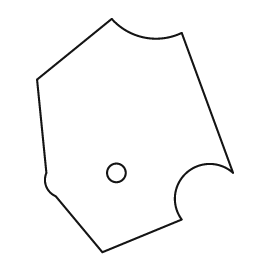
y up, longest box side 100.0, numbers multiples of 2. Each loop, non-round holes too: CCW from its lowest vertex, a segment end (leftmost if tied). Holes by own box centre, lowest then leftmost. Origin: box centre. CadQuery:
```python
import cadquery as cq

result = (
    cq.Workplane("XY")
    .moveTo(-14.0, -50.0)
    .lineTo(20.0, -36.0)
    .threePointArc((22.0, -16.0), (42.0, -16.0))
    .lineTo(20.0, 44.0)
    .threePointArc((4.0, 42.0), (-10.0, 50.0))
    .lineTo(-42.0, 24.0)
    .lineTo(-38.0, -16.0)
    .threePointArc((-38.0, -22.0), (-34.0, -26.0))
    .close()
    .moveTo(-8.0, -16.0)
    .circle(4.0)
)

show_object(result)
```